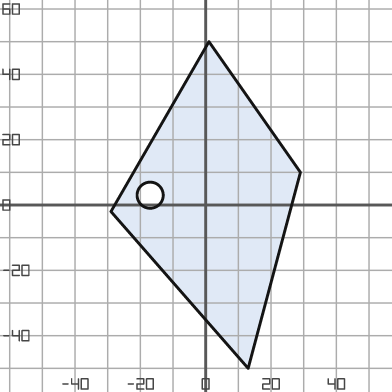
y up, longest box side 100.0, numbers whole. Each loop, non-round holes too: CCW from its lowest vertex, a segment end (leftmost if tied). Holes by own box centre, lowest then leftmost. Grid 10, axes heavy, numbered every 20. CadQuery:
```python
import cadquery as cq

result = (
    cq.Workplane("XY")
    .moveTo(13.0, -50.0)
    .lineTo(29.0, 10.0)
    .lineTo(1.0, 50.0)
    .lineTo(-29.0, -2.0)
    .close()
    .moveTo(-17.0, 3.0)
    .circle(4.0)
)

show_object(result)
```